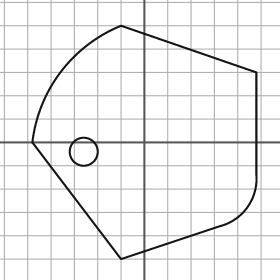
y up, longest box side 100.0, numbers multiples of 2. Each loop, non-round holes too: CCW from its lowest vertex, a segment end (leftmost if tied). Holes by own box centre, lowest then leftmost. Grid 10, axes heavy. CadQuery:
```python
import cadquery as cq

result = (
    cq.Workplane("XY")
    .moveTo(-10.0, -50.0)
    .lineTo(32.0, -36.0)
    .threePointArc((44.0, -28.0), (48.0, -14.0))
    .lineTo(48.0, 30.0)
    .lineTo(-10.0, 50.0)
    .threePointArc((-36.0, 30.0), (-48.0, 0.0))
    .close()
    .moveTo(-26.0, -4.0)
    .circle(6.0)
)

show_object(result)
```